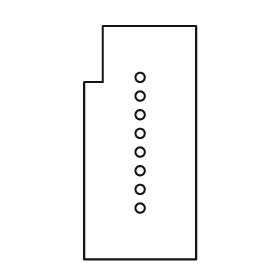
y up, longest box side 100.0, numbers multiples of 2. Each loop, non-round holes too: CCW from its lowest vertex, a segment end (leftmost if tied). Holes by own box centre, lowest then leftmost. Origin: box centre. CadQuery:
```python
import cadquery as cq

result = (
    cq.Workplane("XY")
    .moveTo(-24.0, -50.0)
    .lineTo(24.0, -50.0)
    .lineTo(24.0, 50.0)
    .lineTo(-16.0, 50.0)
    .lineTo(-16.0, 26.0)
    .lineTo(-24.0, 26.0)
    .close()
    .moveTo(0.0, -28.0)
    .circle(2.0)
    .moveTo(0.0, -20.0)
    .circle(2.0)
    .moveTo(0.0, -12.0)
    .circle(2.0)
    .moveTo(0.0, -4.0)
    .circle(2.0)
    .moveTo(0.0, 4.0)
    .circle(2.0)
    .moveTo(0.0, 12.0)
    .circle(2.0)
    .moveTo(0.0, 20.0)
    .circle(2.0)
    .moveTo(0.0, 28.0)
    .circle(2.0)
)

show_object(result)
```